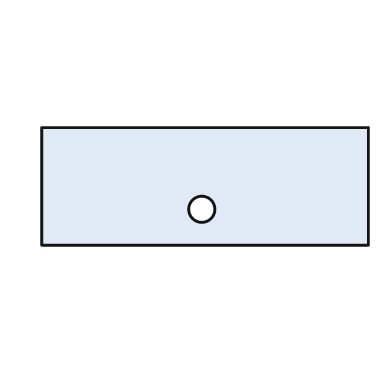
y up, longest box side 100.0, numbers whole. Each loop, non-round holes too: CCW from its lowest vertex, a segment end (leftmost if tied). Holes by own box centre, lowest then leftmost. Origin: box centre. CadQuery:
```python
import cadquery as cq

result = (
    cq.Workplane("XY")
    .moveTo(-50.0, -18.0)
    .lineTo(50.0, -18.0)
    .lineTo(50.0, 18.0)
    .lineTo(-50.0, 18.0)
    .close()
    .moveTo(-1.0, -7.0)
    .circle(4.0)
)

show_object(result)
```